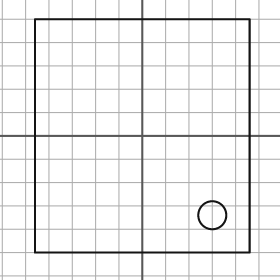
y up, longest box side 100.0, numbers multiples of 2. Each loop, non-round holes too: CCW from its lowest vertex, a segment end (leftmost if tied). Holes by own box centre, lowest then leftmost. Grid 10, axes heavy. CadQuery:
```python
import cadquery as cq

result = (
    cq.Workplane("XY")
    .moveTo(-46.0, -50.0)
    .lineTo(46.0, -50.0)
    .lineTo(46.0, 50.0)
    .lineTo(-46.0, 50.0)
    .close()
    .moveTo(30.0, -34.0)
    .circle(6.0)
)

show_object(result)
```